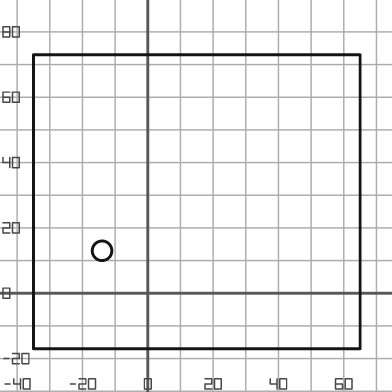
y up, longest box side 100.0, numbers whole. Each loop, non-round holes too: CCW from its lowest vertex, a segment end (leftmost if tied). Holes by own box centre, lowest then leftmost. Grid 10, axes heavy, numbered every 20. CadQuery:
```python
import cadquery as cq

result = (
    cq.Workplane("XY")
    .moveTo(-35.0, -17.0)
    .lineTo(65.0, -17.0)
    .lineTo(65.0, 73.0)
    .lineTo(-35.0, 73.0)
    .close()
    .moveTo(-14.0, 13.0)
    .circle(3.0)
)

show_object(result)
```